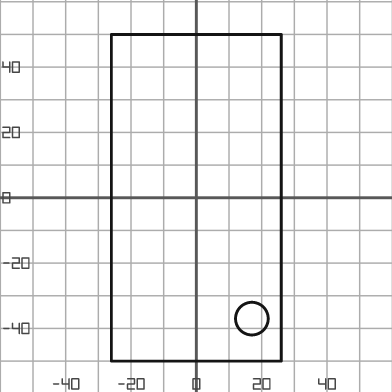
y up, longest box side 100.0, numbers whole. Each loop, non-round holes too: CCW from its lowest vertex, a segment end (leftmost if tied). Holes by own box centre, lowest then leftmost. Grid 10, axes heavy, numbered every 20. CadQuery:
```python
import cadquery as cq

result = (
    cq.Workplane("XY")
    .moveTo(-26.0, -50.0)
    .lineTo(26.0, -50.0)
    .lineTo(26.0, 50.0)
    .lineTo(-26.0, 50.0)
    .close()
    .moveTo(17.0, -37.0)
    .circle(5.0)
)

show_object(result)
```